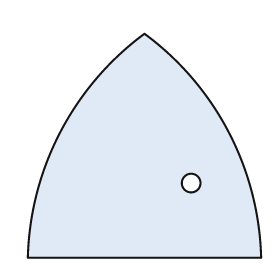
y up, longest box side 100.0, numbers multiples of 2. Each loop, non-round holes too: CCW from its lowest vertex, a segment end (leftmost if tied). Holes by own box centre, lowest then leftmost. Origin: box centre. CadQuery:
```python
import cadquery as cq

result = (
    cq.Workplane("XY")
    .moveTo(-50.0, -48.0)
    .lineTo(50.0, -48.0)
    .threePointArc((36.0, 6.0), (0.0, 48.0))
    .threePointArc((-36.0, 6.0), (-50.0, -48.0))
    .close()
    .moveTo(20.0, -16.0)
    .circle(4.0)
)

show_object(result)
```